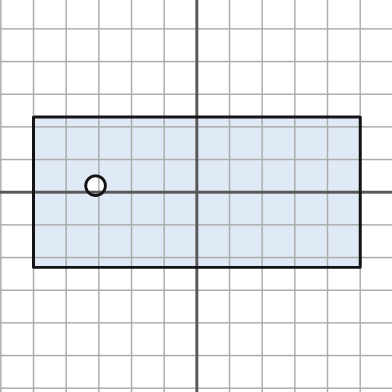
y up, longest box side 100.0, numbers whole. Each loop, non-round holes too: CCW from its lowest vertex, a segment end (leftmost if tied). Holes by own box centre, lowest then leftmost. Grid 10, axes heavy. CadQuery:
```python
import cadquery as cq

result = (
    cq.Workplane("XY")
    .moveTo(-50.0, -23.0)
    .lineTo(50.0, -23.0)
    .lineTo(50.0, 23.0)
    .lineTo(-50.0, 23.0)
    .close()
    .moveTo(-31.0, 2.0)
    .circle(3.0)
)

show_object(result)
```